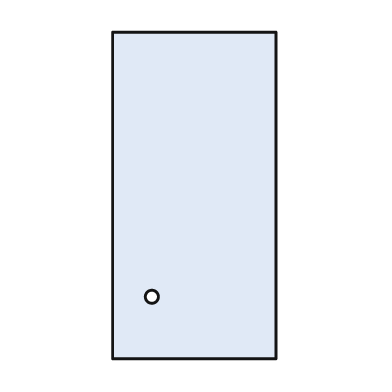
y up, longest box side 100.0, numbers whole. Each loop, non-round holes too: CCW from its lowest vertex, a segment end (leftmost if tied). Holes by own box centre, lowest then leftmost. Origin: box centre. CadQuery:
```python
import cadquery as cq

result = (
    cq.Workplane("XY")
    .moveTo(-25.0, -50.0)
    .lineTo(25.0, -50.0)
    .lineTo(25.0, 50.0)
    .lineTo(-25.0, 50.0)
    .close()
    .moveTo(-13.0, -31.0)
    .circle(2.0)
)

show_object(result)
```